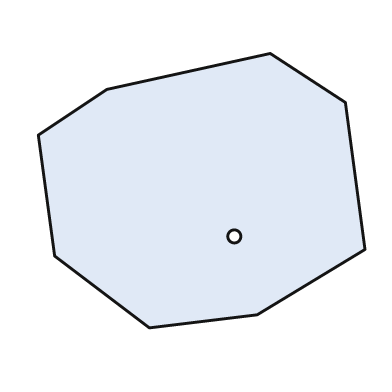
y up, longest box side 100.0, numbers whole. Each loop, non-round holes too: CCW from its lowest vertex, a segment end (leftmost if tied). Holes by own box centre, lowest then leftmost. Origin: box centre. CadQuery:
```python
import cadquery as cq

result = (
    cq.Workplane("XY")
    .moveTo(-16.0, -42.0)
    .lineTo(17.0, -38.0)
    .lineTo(50.0, -18.0)
    .lineTo(44.0, 27.0)
    .lineTo(21.0, 42.0)
    .lineTo(-29.0, 31.0)
    .lineTo(-50.0, 17.0)
    .lineTo(-45.0, -20.0)
    .close()
    .moveTo(10.0, -14.0)
    .circle(2.0)
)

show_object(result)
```